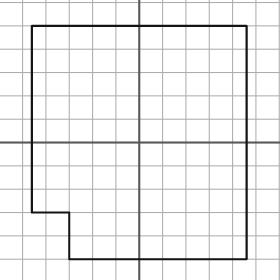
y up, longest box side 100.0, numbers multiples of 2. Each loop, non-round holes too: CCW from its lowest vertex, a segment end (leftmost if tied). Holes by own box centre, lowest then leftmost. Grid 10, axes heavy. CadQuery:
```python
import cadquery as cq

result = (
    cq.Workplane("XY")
    .moveTo(-30.0, -50.0)
    .lineTo(46.0, -50.0)
    .lineTo(46.0, 50.0)
    .lineTo(-46.0, 50.0)
    .lineTo(-46.0, -30.0)
    .lineTo(-30.0, -30.0)
    .close()
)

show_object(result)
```